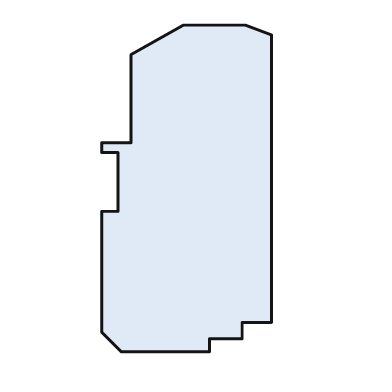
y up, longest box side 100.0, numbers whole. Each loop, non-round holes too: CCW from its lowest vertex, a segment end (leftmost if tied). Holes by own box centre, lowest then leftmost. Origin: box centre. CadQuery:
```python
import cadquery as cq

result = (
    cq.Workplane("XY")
    .moveTo(-20.0, -50.0)
    .lineTo(7.0, -50.0)
    .lineTo(7.0, -46.0)
    .lineTo(17.0, -46.0)
    .lineTo(17.0, -41.0)
    .lineTo(26.0, -41.0)
    .lineTo(26.0, 47.0)
    .lineTo(18.0, 50.0)
    .lineTo(-1.0, 50.0)
    .lineTo(-17.0, 41.0)
    .lineTo(-17.0, 14.0)
    .lineTo(-26.0, 14.0)
    .lineTo(-26.0, 11.0)
    .lineTo(-21.0, 11.0)
    .lineTo(-21.0, -7.0)
    .lineTo(-26.0, -7.0)
    .lineTo(-26.0, -44.0)
    .close()
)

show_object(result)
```